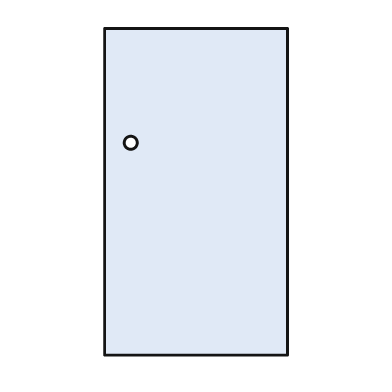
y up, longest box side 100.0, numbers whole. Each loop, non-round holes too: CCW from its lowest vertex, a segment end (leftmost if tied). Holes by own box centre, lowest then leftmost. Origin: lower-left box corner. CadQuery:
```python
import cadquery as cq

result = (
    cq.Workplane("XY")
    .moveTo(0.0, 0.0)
    .lineTo(56.0, 0.0)
    .lineTo(56.0, 100.0)
    .lineTo(0.0, 100.0)
    .close()
    .moveTo(8.0, 65.0)
    .circle(2.0)
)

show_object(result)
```